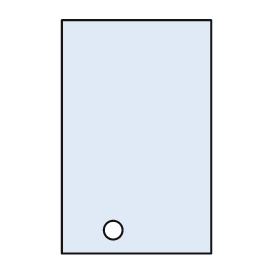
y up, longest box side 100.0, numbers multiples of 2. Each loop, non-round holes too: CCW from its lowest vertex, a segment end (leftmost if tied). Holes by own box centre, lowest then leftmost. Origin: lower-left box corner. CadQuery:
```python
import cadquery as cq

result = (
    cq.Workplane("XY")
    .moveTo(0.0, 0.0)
    .lineTo(64.0, 0.0)
    .lineTo(64.0, 100.0)
    .lineTo(0.0, 100.0)
    .close()
    .moveTo(22.0, 10.0)
    .circle(4.0)
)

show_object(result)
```